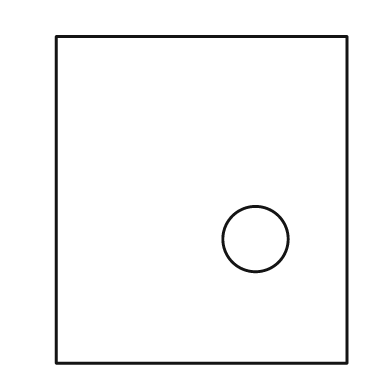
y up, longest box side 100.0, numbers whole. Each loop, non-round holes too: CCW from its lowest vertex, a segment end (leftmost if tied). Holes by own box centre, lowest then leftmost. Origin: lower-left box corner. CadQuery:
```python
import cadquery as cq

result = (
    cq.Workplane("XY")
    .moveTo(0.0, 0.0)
    .lineTo(89.0, 0.0)
    .lineTo(89.0, 100.0)
    .lineTo(0.0, 100.0)
    .close()
    .moveTo(61.0, 38.0)
    .circle(10.0)
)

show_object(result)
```